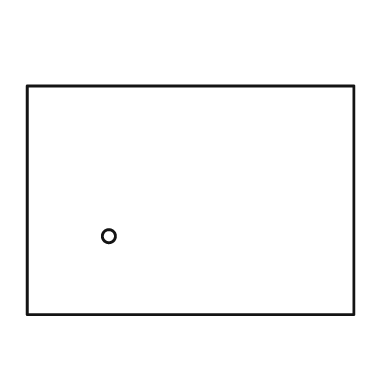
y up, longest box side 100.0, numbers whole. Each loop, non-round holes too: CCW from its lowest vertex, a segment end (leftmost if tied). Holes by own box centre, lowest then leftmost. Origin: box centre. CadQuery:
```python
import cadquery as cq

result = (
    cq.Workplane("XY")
    .moveTo(-50.0, -35.0)
    .lineTo(50.0, -35.0)
    .lineTo(50.0, 35.0)
    .lineTo(-50.0, 35.0)
    .close()
    .moveTo(-25.0, -11.0)
    .circle(2.0)
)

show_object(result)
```